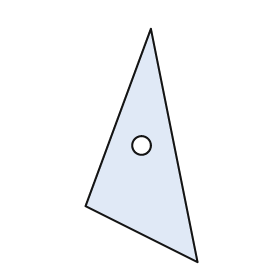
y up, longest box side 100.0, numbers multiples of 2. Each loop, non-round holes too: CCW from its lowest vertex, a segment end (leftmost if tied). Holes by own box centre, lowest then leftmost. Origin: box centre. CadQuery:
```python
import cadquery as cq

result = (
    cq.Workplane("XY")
    .moveTo(24.0, -50.0)
    .lineTo(4.0, 50.0)
    .lineTo(-24.0, -26.0)
    .close()
    .moveTo(0.0, 0.0)
    .circle(4.0)
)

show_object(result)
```